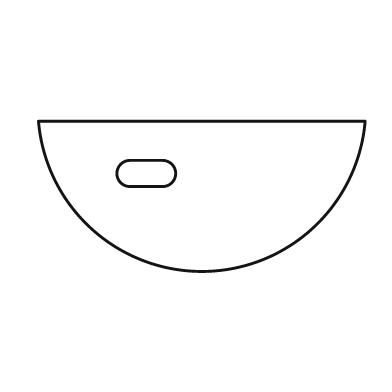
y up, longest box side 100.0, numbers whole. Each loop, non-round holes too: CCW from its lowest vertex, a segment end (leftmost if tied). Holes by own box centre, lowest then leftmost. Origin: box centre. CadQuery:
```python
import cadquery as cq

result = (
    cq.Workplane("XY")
    .moveTo(-50.0, 23.0)
    .threePointArc((0.0, -23.0), (50.0, 23.0))
    .close()
    .moveTo(-22.0, 3.0)
    .lineTo(-12.0, 3.0)
    .threePointArc((-8.0, 7.0), (-12.0, 11.0))
    .lineTo(-22.0, 11.0)
    .threePointArc((-26.0, 7.0), (-22.0, 3.0))
    .close()
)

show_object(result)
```